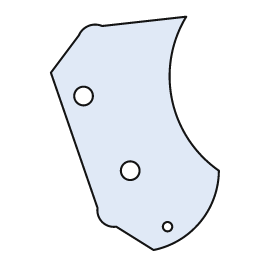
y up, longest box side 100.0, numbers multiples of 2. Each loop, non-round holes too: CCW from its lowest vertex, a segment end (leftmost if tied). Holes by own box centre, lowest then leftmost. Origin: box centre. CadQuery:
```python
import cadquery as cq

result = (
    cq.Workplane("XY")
    .moveTo(8.0, -50.0)
    .threePointArc((28.0, -38.0), (36.0, -16.0))
    .threePointArc((16.0, 14.0), (22.0, 50.0))
    .lineTo(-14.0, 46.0)
    .threePointArc((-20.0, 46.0), (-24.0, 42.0))
    .lineTo(-36.0, 26.0)
    .lineTo(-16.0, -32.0)
    .threePointArc((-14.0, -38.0), (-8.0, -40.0))
    .close()
    .moveTo(14.0, -40.0)
    .circle(2.0)
    .moveTo(-2.0, -16.0)
    .circle(4.0)
    .moveTo(-22.0, 16.0)
    .circle(4.0)
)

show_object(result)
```